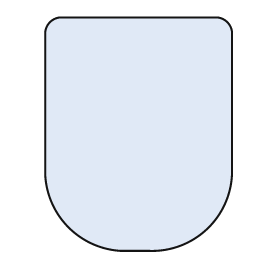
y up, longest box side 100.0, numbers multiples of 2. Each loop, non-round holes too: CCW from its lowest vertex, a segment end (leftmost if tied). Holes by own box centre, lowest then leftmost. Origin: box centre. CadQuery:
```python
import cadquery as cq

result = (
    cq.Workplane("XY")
    .moveTo(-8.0, -50.0)
    .lineTo(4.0, -50.0)
    .threePointArc((30.0, -40.0), (40.0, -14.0))
    .lineTo(40.0, 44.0)
    .threePointArc((38.0, 48.0), (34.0, 50.0))
    .lineTo(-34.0, 50.0)
    .threePointArc((-38.0, 48.0), (-40.0, 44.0))
    .lineTo(-40.0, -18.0)
    .threePointArc((-30.0, -40.0), (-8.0, -50.0))
    .close()
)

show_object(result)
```